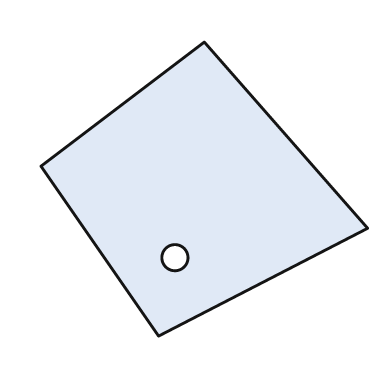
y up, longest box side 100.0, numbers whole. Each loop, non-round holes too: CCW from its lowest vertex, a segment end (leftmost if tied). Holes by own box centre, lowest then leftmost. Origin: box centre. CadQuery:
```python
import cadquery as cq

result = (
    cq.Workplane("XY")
    .moveTo(-14.0, -45.0)
    .lineTo(50.0, -12.0)
    .lineTo(0.0, 45.0)
    .lineTo(-50.0, 7.0)
    .close()
    .moveTo(-9.0, -21.0)
    .circle(4.0)
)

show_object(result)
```